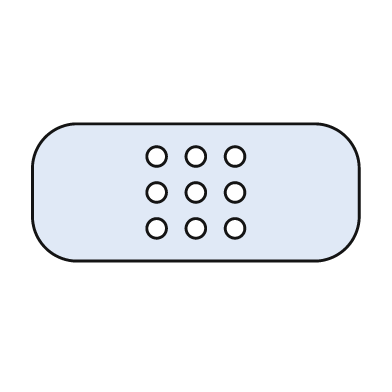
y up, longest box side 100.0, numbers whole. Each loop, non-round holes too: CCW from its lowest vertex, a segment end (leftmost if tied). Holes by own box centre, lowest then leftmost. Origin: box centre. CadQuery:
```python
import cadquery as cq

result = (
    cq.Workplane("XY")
    .moveTo(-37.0, -21.0)
    .lineTo(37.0, -21.0)
    .threePointArc((46.0, -17.0), (50.0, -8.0))
    .lineTo(50.0, 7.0)
    .threePointArc((46.0, 17.0), (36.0, 21.0))
    .lineTo(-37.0, 21.0)
    .threePointArc((-46.0, 17.0), (-50.0, 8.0))
    .lineTo(-50.0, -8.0)
    .threePointArc((-46.0, -17.0), (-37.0, -21.0))
    .close()
    .moveTo(-12.0, -11.0)
    .circle(3.0)
    .moveTo(0.0, -11.0)
    .circle(3.0)
    .moveTo(12.0, -11.0)
    .circle(3.0)
    .moveTo(-12.0, 0.0)
    .circle(3.0)
    .moveTo(0.0, 0.0)
    .circle(3.0)
    .moveTo(12.0, 0.0)
    .circle(3.0)
    .moveTo(-12.0, 11.0)
    .circle(3.0)
    .moveTo(0.0, 11.0)
    .circle(3.0)
    .moveTo(12.0, 11.0)
    .circle(3.0)
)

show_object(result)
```